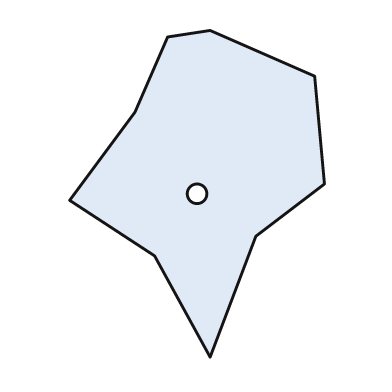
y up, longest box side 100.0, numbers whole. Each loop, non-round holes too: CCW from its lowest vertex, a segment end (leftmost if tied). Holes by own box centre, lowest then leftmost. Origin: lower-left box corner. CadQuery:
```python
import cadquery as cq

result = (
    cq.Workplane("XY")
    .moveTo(43.0, 0.0)
    .lineTo(57.0, 37.0)
    .lineTo(78.0, 53.0)
    .lineTo(75.0, 86.0)
    .lineTo(43.0, 100.0)
    .lineTo(30.0, 98.0)
    .lineTo(20.0, 75.0)
    .lineTo(0.0, 48.0)
    .lineTo(26.0, 31.0)
    .close()
    .moveTo(39.0, 50.0)
    .circle(3.0)
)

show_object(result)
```